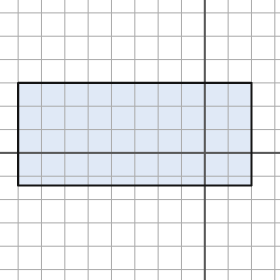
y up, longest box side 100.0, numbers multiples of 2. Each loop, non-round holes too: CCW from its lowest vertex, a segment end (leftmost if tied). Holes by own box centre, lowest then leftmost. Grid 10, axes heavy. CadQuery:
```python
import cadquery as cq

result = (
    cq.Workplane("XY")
    .moveTo(-80.0, -14.0)
    .lineTo(20.0, -14.0)
    .lineTo(20.0, 30.0)
    .lineTo(-80.0, 30.0)
    .close()
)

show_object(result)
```